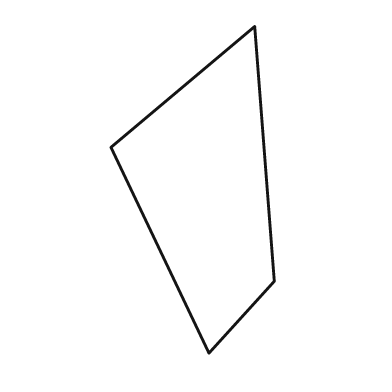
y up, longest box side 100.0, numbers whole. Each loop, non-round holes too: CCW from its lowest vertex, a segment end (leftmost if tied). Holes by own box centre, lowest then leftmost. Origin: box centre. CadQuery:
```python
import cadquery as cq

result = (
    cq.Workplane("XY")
    .moveTo(5.0, -50.0)
    .lineTo(25.0, -28.0)
    .lineTo(19.0, 50.0)
    .lineTo(-25.0, 13.0)
    .close()
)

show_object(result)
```